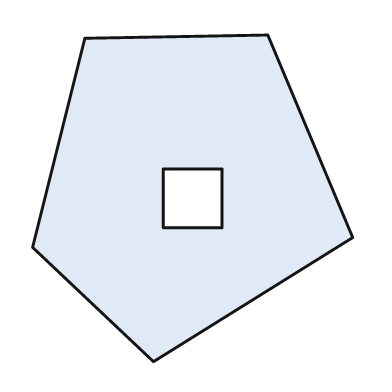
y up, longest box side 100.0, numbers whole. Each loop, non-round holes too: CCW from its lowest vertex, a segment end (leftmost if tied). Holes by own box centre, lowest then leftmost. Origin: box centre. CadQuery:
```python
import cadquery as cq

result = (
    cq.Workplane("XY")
    .moveTo(-12.0, -50.0)
    .lineTo(49.0, -12.0)
    .lineTo(23.0, 50.0)
    .lineTo(-33.0, 49.0)
    .lineTo(-49.0, -15.0)
    .close()
    .moveTo(-9.0, -9.0)
    .lineTo(9.0, -9.0)
    .lineTo(9.0, 9.0)
    .lineTo(-9.0, 9.0)
    .close()
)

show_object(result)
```